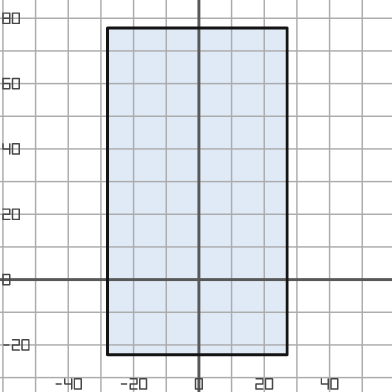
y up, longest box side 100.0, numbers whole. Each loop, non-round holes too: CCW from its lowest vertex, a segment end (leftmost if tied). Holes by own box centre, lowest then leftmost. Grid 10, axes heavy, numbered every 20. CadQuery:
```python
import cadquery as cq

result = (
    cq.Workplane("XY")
    .moveTo(-28.0, -23.0)
    .lineTo(27.0, -23.0)
    .lineTo(27.0, 77.0)
    .lineTo(-28.0, 77.0)
    .close()
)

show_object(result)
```